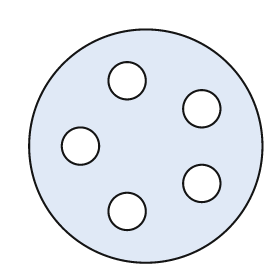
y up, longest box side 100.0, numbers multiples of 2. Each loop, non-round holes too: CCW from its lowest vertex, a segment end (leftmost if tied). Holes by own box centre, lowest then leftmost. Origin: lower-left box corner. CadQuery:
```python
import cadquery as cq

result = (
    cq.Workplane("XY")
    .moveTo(50.0, 50.0)
    .circle(50.0)
    .moveTo(42.0, 22.0)
    .circle(8.0)
    .moveTo(74.0, 34.0)
    .circle(8.0)
    .moveTo(22.0, 50.0)
    .circle(8.0)
    .moveTo(74.0, 66.0)
    .circle(8.0)
    .moveTo(42.0, 78.0)
    .circle(8.0)
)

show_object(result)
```